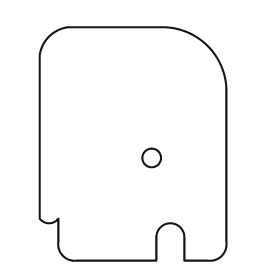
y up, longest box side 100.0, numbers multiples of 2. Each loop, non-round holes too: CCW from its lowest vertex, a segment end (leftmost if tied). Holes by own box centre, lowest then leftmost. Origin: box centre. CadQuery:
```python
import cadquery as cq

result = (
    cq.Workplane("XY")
    .moveTo(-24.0, -50.0)
    .lineTo(10.0, -50.0)
    .lineTo(10.0, -40.0)
    .threePointArc((16.0, -34.0), (22.0, -40.0))
    .lineTo(22.0, -50.0)
    .lineTo(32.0, -50.0)
    .threePointArc((38.0, -48.0), (40.0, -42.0))
    .lineTo(40.0, 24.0)
    .threePointArc((32.0, 42.0), (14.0, 50.0))
    .lineTo(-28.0, 50.0)
    .threePointArc((-36.0, 46.0), (-40.0, 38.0))
    .lineTo(-40.0, -32.0)
    .threePointArc((-36.0, -34.0), (-32.0, -32.0))
    .lineTo(-32.0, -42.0)
    .threePointArc((-30.0, -48.0), (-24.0, -50.0))
    .close()
    .moveTo(8.0, -6.0)
    .circle(4.0)
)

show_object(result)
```